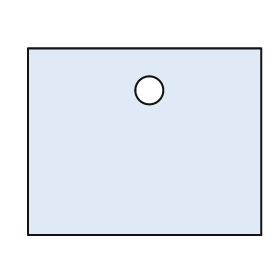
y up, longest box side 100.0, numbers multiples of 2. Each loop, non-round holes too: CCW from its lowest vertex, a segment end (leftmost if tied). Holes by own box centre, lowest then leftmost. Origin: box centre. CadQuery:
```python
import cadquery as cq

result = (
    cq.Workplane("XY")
    .moveTo(-50.0, -40.0)
    .lineTo(50.0, -40.0)
    .lineTo(50.0, 40.0)
    .lineTo(-50.0, 40.0)
    .close()
    .moveTo(2.0, 22.0)
    .circle(6.0)
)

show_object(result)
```